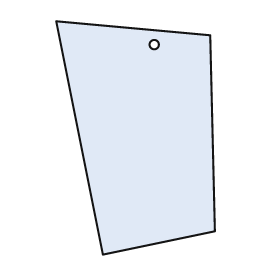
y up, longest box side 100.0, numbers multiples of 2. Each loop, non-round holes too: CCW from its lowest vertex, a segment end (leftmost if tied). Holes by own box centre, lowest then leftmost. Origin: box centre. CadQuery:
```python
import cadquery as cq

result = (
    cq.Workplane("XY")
    .moveTo(-14.0, -50.0)
    .lineTo(34.0, -40.0)
    .lineTo(32.0, 44.0)
    .lineTo(-34.0, 50.0)
    .close()
    .moveTo(8.0, 40.0)
    .circle(2.0)
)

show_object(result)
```